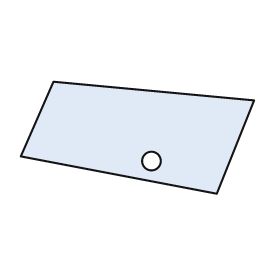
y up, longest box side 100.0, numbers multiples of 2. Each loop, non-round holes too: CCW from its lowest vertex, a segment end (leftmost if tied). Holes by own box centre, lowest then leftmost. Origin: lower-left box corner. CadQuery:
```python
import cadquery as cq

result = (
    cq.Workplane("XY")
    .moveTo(84.0, 0.0)
    .lineTo(100.0, 40.0)
    .lineTo(14.0, 48.0)
    .lineTo(0.0, 16.0)
    .close()
    .moveTo(56.0, 14.0)
    .circle(4.0)
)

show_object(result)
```